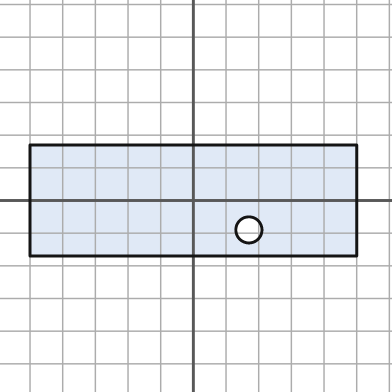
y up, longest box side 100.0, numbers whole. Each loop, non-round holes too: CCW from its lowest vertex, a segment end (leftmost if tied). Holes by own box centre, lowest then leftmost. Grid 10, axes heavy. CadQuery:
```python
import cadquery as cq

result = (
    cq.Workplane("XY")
    .moveTo(-50.0, -17.0)
    .lineTo(50.0, -17.0)
    .lineTo(50.0, 17.0)
    .lineTo(-50.0, 17.0)
    .close()
    .moveTo(17.0, -9.0)
    .circle(4.0)
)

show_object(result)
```